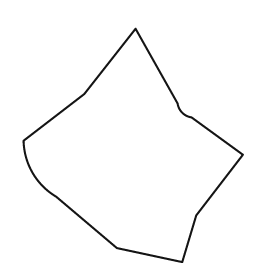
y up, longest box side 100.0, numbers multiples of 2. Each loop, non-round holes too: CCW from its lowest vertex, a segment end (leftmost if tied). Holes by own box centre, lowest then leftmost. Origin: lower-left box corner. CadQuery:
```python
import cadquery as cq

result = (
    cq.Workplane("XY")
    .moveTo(68.0, 0.0)
    .lineTo(74.0, 20.0)
    .lineTo(94.0, 46.0)
    .lineTo(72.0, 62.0)
    .threePointArc((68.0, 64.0), (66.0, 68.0))
    .lineTo(48.0, 100.0)
    .lineTo(26.0, 72.0)
    .lineTo(0.0, 52.0)
    .threePointArc((4.0, 38.0), (14.0, 28.0))
    .lineTo(40.0, 6.0)
    .close()
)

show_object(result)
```